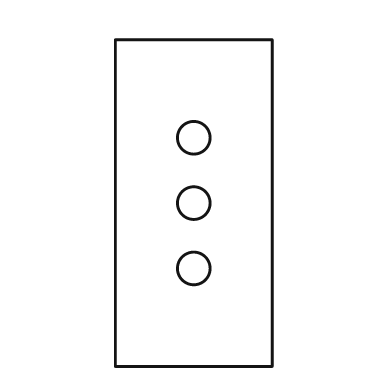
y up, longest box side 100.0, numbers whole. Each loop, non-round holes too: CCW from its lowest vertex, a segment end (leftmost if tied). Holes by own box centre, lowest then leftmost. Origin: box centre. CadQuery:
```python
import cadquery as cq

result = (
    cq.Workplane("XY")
    .moveTo(-24.0, -50.0)
    .lineTo(24.0, -50.0)
    .lineTo(24.0, 50.0)
    .lineTo(-24.0, 50.0)
    .close()
    .moveTo(0.0, -20.0)
    .circle(5.0)
    .moveTo(0.0, 0.0)
    .circle(5.0)
    .moveTo(0.0, 20.0)
    .circle(5.0)
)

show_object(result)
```